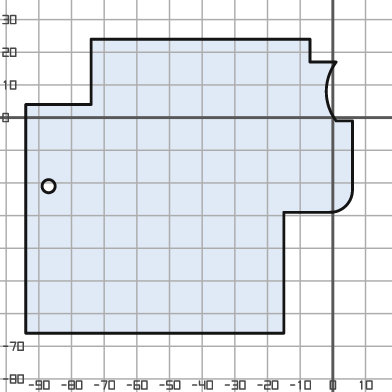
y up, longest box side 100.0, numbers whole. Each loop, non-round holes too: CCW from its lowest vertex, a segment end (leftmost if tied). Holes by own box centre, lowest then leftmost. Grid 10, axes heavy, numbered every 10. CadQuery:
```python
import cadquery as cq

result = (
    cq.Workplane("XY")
    .moveTo(-94.0, -66.0)
    .lineTo(-15.0, -66.0)
    .lineTo(-15.0, -29.0)
    .lineTo(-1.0, -29.0)
    .threePointArc((4.0, -27.0), (6.0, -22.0))
    .lineTo(6.0, -1.0)
    .lineTo(1.0, -1.0)
    .threePointArc((-2.0, 8.0), (1.0, 17.0))
    .lineTo(-7.0, 17.0)
    .lineTo(-7.0, 24.0)
    .lineTo(-74.0, 24.0)
    .lineTo(-74.0, 4.0)
    .lineTo(-94.0, 4.0)
    .close()
    .moveTo(-87.0, -21.0)
    .circle(2.0)
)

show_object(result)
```